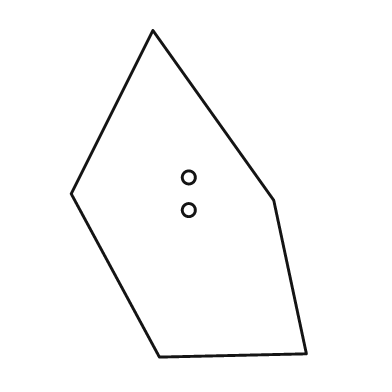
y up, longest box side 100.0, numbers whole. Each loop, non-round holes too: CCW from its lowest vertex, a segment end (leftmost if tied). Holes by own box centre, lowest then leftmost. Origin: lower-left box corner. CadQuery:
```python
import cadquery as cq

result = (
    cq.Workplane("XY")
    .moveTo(27.0, 0.0)
    .lineTo(72.0, 1.0)
    .lineTo(62.0, 48.0)
    .lineTo(25.0, 100.0)
    .lineTo(0.0, 50.0)
    .close()
    .moveTo(36.0, 45.0)
    .circle(2.0)
    .moveTo(36.0, 55.0)
    .circle(2.0)
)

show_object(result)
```